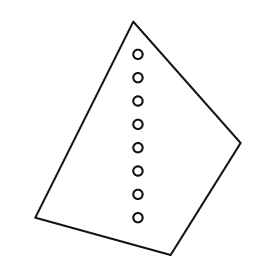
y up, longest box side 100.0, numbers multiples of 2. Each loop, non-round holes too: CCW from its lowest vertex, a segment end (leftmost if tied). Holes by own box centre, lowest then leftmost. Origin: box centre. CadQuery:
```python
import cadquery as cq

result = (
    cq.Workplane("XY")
    .moveTo(14.0, -50.0)
    .lineTo(44.0, -2.0)
    .lineTo(-2.0, 50.0)
    .lineTo(-44.0, -34.0)
    .close()
    .moveTo(0.0, -34.0)
    .circle(2.0)
    .moveTo(0.0, -24.0)
    .circle(2.0)
    .moveTo(0.0, -14.0)
    .circle(2.0)
    .moveTo(0.0, -4.0)
    .circle(2.0)
    .moveTo(0.0, 6.0)
    .circle(2.0)
    .moveTo(0.0, 16.0)
    .circle(2.0)
    .moveTo(0.0, 26.0)
    .circle(2.0)
    .moveTo(0.0, 36.0)
    .circle(2.0)
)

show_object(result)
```